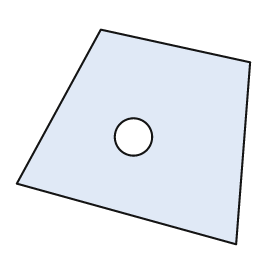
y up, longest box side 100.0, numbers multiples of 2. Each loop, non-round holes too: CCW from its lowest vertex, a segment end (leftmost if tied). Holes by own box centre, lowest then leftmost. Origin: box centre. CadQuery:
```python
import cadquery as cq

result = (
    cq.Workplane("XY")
    .moveTo(44.0, -46.0)
    .lineTo(50.0, 32.0)
    .lineTo(-14.0, 46.0)
    .lineTo(-50.0, -20.0)
    .close()
    .moveTo(0.0, 0.0)
    .circle(8.0)
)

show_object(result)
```